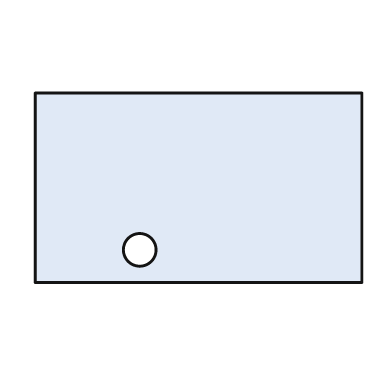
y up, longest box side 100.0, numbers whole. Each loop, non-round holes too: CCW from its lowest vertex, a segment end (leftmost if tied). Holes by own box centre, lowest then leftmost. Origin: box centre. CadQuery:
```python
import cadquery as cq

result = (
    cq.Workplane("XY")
    .moveTo(-50.0, -29.0)
    .lineTo(50.0, -29.0)
    .lineTo(50.0, 29.0)
    .lineTo(-50.0, 29.0)
    .close()
    .moveTo(-18.0, -19.0)
    .circle(5.0)
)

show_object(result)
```